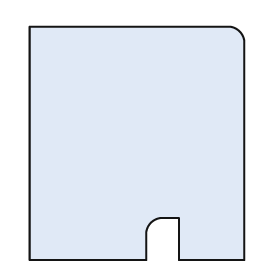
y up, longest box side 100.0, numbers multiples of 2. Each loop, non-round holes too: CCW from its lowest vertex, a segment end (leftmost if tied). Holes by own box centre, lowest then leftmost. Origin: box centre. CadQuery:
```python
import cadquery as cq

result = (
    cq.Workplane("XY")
    .moveTo(-46.0, -50.0)
    .lineTo(4.0, -50.0)
    .lineTo(4.0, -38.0)
    .threePointArc((6.0, -34.0), (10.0, -32.0))
    .lineTo(18.0, -32.0)
    .lineTo(18.0, -50.0)
    .lineTo(46.0, -50.0)
    .lineTo(46.0, 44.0)
    .threePointArc((44.0, 48.0), (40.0, 50.0))
    .lineTo(-46.0, 50.0)
    .close()
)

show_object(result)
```